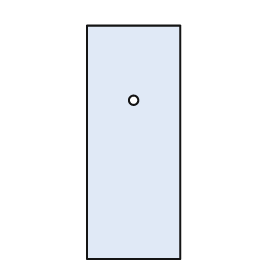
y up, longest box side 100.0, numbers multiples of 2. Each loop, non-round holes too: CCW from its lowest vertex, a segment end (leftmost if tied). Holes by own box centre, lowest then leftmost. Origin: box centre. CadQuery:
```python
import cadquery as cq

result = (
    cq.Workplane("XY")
    .moveTo(-20.0, -50.0)
    .lineTo(20.0, -50.0)
    .lineTo(20.0, 50.0)
    .lineTo(-20.0, 50.0)
    .close()
    .moveTo(0.0, 18.0)
    .circle(2.0)
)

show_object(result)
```